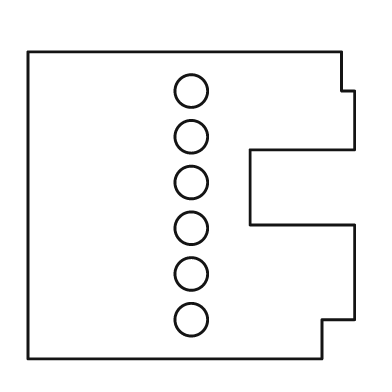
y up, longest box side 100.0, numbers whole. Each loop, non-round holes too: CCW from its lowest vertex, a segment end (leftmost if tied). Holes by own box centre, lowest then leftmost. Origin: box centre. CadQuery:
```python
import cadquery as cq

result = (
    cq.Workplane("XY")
    .moveTo(-50.0, -47.0)
    .lineTo(40.0, -47.0)
    .lineTo(40.0, -35.0)
    .lineTo(50.0, -35.0)
    .lineTo(50.0, -6.0)
    .lineTo(18.0, -6.0)
    .lineTo(18.0, 17.0)
    .lineTo(50.0, 17.0)
    .lineTo(50.0, 35.0)
    .lineTo(46.0, 35.0)
    .lineTo(46.0, 47.0)
    .lineTo(-50.0, 47.0)
    .close()
    .moveTo(0.0, -35.0)
    .circle(5.0)
    .moveTo(0.0, -21.0)
    .circle(5.0)
    .moveTo(0.0, -7.0)
    .circle(5.0)
    .moveTo(0.0, 7.0)
    .circle(5.0)
    .moveTo(0.0, 21.0)
    .circle(5.0)
    .moveTo(0.0, 35.0)
    .circle(5.0)
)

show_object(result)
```